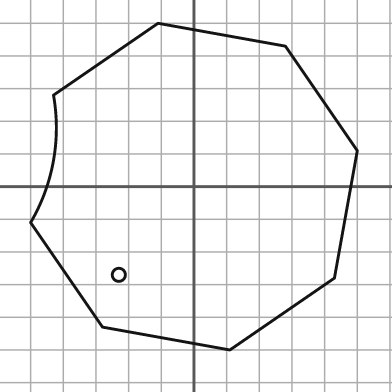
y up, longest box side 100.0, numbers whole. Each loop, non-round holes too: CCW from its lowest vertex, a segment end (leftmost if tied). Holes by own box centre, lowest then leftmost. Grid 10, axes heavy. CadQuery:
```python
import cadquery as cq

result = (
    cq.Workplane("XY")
    .moveTo(11.0, -50.0)
    .lineTo(43.0, -28.0)
    .lineTo(50.0, 11.0)
    .lineTo(28.0, 43.0)
    .lineTo(-11.0, 50.0)
    .lineTo(-43.0, 28.0)
    .threePointArc((-43.0, 8.0), (-50.0, -11.0))
    .lineTo(-28.0, -43.0)
    .close()
    .moveTo(-23.0, -27.0)
    .circle(2.0)
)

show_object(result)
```